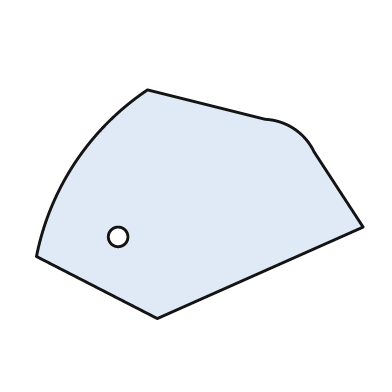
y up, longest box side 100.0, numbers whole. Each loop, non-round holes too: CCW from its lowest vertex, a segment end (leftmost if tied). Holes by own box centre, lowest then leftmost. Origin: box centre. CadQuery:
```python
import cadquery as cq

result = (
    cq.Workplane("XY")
    .moveTo(-13.0, -35.0)
    .lineTo(50.0, -7.0)
    .lineTo(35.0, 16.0)
    .threePointArc((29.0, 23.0), (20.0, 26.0))
    .lineTo(-16.0, 35.0)
    .threePointArc((-38.0, 13.0), (-50.0, -16.0))
    .close()
    .moveTo(-25.0, -10.0)
    .circle(3.0)
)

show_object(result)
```